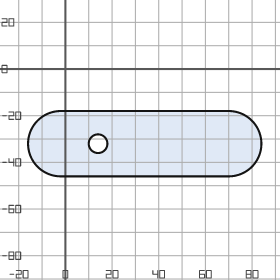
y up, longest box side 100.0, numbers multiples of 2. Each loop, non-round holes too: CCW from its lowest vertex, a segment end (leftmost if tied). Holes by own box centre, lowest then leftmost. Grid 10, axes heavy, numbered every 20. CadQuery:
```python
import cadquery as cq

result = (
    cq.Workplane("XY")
    .moveTo(-2.0, -46.0)
    .lineTo(70.0, -46.0)
    .threePointArc((84.0, -32.0), (70.0, -18.0))
    .lineTo(-2.0, -18.0)
    .threePointArc((-16.0, -32.0), (-2.0, -46.0))
    .close()
    .moveTo(14.0, -32.0)
    .circle(4.0)
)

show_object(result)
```